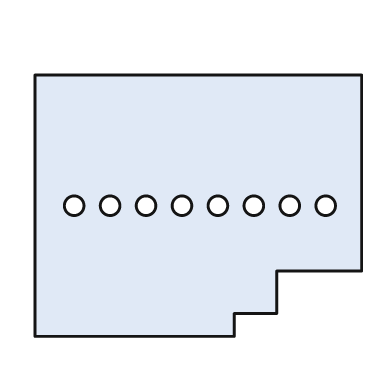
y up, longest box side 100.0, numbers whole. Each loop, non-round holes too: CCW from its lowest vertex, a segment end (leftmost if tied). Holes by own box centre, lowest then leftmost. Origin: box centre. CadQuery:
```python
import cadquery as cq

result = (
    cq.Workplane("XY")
    .moveTo(-50.0, -40.0)
    .lineTo(11.0, -40.0)
    .lineTo(11.0, -33.0)
    .lineTo(24.0, -33.0)
    .lineTo(24.0, -20.0)
    .lineTo(50.0, -20.0)
    .lineTo(50.0, 40.0)
    .lineTo(-50.0, 40.0)
    .close()
    .moveTo(-38.0, 0.0)
    .circle(3.0)
    .moveTo(-27.0, 0.0)
    .circle(3.0)
    .moveTo(-16.0, 0.0)
    .circle(3.0)
    .moveTo(-5.0, 0.0)
    .circle(3.0)
    .moveTo(6.0, 0.0)
    .circle(3.0)
    .moveTo(17.0, 0.0)
    .circle(3.0)
    .moveTo(28.0, 0.0)
    .circle(3.0)
    .moveTo(39.0, 0.0)
    .circle(3.0)
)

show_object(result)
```